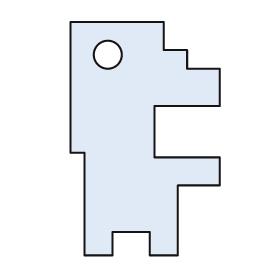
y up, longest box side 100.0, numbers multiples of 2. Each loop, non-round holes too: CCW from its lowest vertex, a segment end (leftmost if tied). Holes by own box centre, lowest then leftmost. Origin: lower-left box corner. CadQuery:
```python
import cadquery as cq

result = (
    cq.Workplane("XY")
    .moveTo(6.0, 0.0)
    .lineTo(18.0, 0.0)
    .lineTo(18.0, 10.0)
    .lineTo(34.0, 10.0)
    .lineTo(34.0, 0.0)
    .lineTo(46.0, 0.0)
    .lineTo(46.0, 30.0)
    .lineTo(64.0, 30.0)
    .lineTo(64.0, 42.0)
    .lineTo(36.0, 42.0)
    .lineTo(36.0, 64.0)
    .lineTo(64.0, 64.0)
    .lineTo(64.0, 80.0)
    .lineTo(50.0, 80.0)
    .lineTo(50.0, 88.0)
    .lineTo(40.0, 88.0)
    .lineTo(40.0, 100.0)
    .lineTo(0.0, 100.0)
    .lineTo(0.0, 44.0)
    .lineTo(6.0, 44.0)
    .close()
    .moveTo(16.0, 86.0)
    .circle(6.0)
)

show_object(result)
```